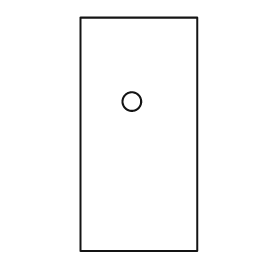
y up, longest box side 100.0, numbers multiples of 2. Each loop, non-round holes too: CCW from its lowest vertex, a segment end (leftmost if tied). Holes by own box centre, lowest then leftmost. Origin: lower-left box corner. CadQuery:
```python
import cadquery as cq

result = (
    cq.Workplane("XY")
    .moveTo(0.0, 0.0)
    .lineTo(50.0, 0.0)
    .lineTo(50.0, 100.0)
    .lineTo(0.0, 100.0)
    .close()
    .moveTo(22.0, 64.0)
    .circle(4.0)
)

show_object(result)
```